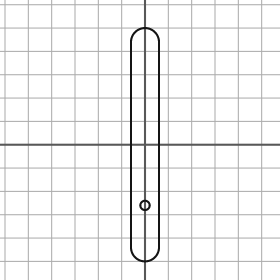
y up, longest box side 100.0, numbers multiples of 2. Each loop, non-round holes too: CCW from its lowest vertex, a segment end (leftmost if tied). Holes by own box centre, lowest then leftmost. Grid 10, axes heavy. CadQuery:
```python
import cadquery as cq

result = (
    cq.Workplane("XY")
    .moveTo(-6.0, -44.0)
    .threePointArc((0.0, -50.0), (6.0, -44.0))
    .lineTo(6.0, 44.0)
    .threePointArc((0.0, 50.0), (-6.0, 44.0))
    .close()
    .moveTo(0.0, -26.0)
    .circle(2.0)
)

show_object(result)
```